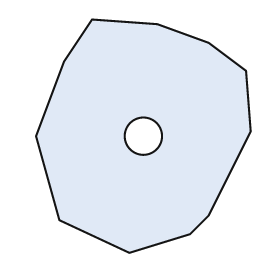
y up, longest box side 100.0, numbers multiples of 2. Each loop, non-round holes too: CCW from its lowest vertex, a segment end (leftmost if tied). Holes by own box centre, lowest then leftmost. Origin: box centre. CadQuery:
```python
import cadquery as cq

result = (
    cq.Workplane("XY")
    .moveTo(-6.0, -50.0)
    .lineTo(20.0, -42.0)
    .lineTo(28.0, -34.0)
    .lineTo(46.0, 2.0)
    .lineTo(44.0, 28.0)
    .lineTo(28.0, 40.0)
    .lineTo(6.0, 48.0)
    .lineTo(-22.0, 50.0)
    .lineTo(-34.0, 32.0)
    .lineTo(-46.0, 0.0)
    .lineTo(-36.0, -36.0)
    .close()
    .moveTo(0.0, 0.0)
    .circle(8.0)
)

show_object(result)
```